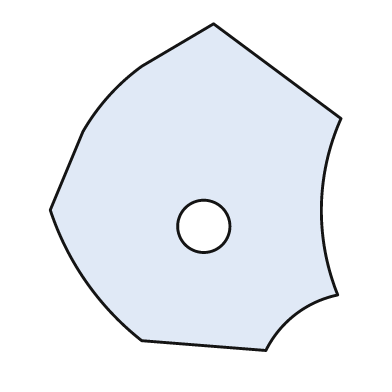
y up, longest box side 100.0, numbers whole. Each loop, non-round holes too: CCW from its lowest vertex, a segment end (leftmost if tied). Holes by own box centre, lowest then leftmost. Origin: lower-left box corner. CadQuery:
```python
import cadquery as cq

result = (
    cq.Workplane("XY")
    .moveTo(66.0, 0.0)
    .threePointArc((75.0, 11.0), (88.0, 17.0))
    .threePointArc((83.0, 44.0), (89.0, 71.0))
    .lineTo(50.0, 100.0)
    .lineTo(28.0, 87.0)
    .threePointArc((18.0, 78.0), (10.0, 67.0))
    .lineTo(0.0, 43.0)
    .threePointArc((11.0, 21.0), (28.0, 3.0))
    .close()
    .moveTo(47.0, 38.0)
    .circle(8.0)
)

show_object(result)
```